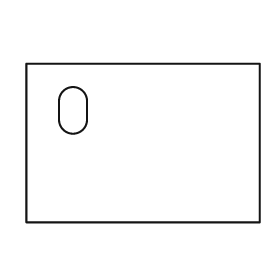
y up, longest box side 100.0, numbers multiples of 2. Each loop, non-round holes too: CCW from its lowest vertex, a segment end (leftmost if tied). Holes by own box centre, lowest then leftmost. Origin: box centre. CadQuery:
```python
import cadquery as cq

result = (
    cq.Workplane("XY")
    .moveTo(-50.0, -34.0)
    .lineTo(50.0, -34.0)
    .lineTo(50.0, 34.0)
    .lineTo(-50.0, 34.0)
    .close()
    .moveTo(-36.0, 10.0)
    .threePointArc((-30.0, 4.0), (-24.0, 10.0))
    .lineTo(-24.0, 18.0)
    .threePointArc((-30.0, 24.0), (-36.0, 18.0))
    .close()
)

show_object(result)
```